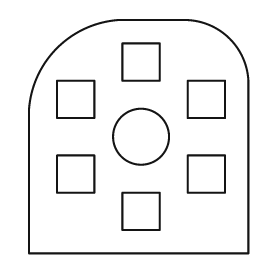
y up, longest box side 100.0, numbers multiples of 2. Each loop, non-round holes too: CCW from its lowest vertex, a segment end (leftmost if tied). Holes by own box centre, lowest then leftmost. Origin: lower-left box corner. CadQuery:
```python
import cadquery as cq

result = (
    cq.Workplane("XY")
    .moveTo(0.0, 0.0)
    .lineTo(94.0, 0.0)
    .lineTo(94.0, 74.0)
    .threePointArc((86.0, 92.0), (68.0, 100.0))
    .lineTo(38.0, 100.0)
    .threePointArc((12.0, 88.0), (0.0, 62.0))
    .close()
    .moveTo(40.0, 10.0)
    .lineTo(56.0, 10.0)
    .lineTo(56.0, 26.0)
    .lineTo(40.0, 26.0)
    .close()
    .moveTo(12.0, 26.0)
    .lineTo(28.0, 26.0)
    .lineTo(28.0, 42.0)
    .lineTo(12.0, 42.0)
    .close()
    .moveTo(68.0, 26.0)
    .lineTo(84.0, 26.0)
    .lineTo(84.0, 42.0)
    .lineTo(68.0, 42.0)
    .close()
    .moveTo(48.0, 50.0)
    .circle(12.0)
    .moveTo(12.0, 58.0)
    .lineTo(28.0, 58.0)
    .lineTo(28.0, 74.0)
    .lineTo(12.0, 74.0)
    .close()
    .moveTo(68.0, 58.0)
    .lineTo(84.0, 58.0)
    .lineTo(84.0, 74.0)
    .lineTo(68.0, 74.0)
    .close()
    .moveTo(40.0, 74.0)
    .lineTo(56.0, 74.0)
    .lineTo(56.0, 90.0)
    .lineTo(40.0, 90.0)
    .close()
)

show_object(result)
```